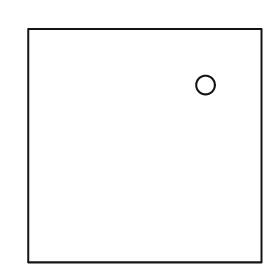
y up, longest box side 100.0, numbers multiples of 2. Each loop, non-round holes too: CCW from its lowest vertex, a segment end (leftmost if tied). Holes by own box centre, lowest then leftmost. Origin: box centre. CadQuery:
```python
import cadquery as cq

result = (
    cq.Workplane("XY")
    .moveTo(-50.0, -50.0)
    .lineTo(50.0, -50.0)
    .lineTo(50.0, 50.0)
    .lineTo(-50.0, 50.0)
    .close()
    .moveTo(26.0, 26.0)
    .circle(4.0)
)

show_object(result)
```